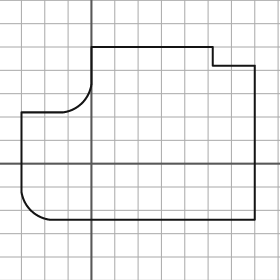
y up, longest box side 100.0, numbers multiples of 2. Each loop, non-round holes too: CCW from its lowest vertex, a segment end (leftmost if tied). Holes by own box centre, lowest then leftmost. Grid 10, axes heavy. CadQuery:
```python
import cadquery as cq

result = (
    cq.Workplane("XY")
    .moveTo(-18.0, -24.0)
    .lineTo(70.0, -24.0)
    .lineTo(70.0, 42.0)
    .lineTo(52.0, 42.0)
    .lineTo(52.0, 50.0)
    .lineTo(0.0, 50.0)
    .lineTo(0.0, 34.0)
    .threePointArc((-4.0, 26.0), (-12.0, 22.0))
    .lineTo(-30.0, 22.0)
    .lineTo(-30.0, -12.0)
    .threePointArc((-26.0, -20.0), (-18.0, -24.0))
    .close()
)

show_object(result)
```